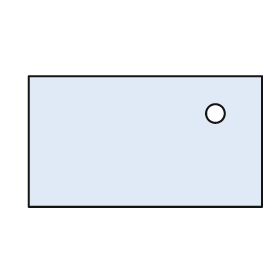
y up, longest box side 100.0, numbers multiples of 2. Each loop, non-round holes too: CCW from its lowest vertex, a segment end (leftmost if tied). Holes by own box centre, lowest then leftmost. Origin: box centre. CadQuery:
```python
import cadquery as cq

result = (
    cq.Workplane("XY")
    .moveTo(-50.0, -28.0)
    .lineTo(50.0, -28.0)
    .lineTo(50.0, 28.0)
    .lineTo(-50.0, 28.0)
    .close()
    .moveTo(30.0, 12.0)
    .circle(4.0)
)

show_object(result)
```